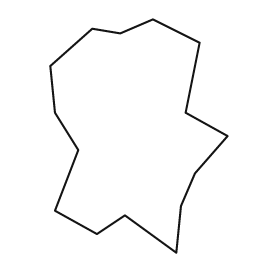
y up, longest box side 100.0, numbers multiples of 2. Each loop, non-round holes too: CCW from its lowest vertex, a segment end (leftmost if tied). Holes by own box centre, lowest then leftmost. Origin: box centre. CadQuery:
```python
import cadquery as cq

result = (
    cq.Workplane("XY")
    .moveTo(16.0, -50.0)
    .lineTo(18.0, -30.0)
    .lineTo(24.0, -16.0)
    .lineTo(38.0, 0.0)
    .lineTo(20.0, 10.0)
    .lineTo(26.0, 40.0)
    .lineTo(6.0, 50.0)
    .lineTo(-8.0, 44.0)
    .lineTo(-20.0, 46.0)
    .lineTo(-38.0, 30.0)
    .lineTo(-36.0, 10.0)
    .lineTo(-26.0, -6.0)
    .lineTo(-36.0, -32.0)
    .lineTo(-18.0, -42.0)
    .lineTo(-6.0, -34.0)
    .close()
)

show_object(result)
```